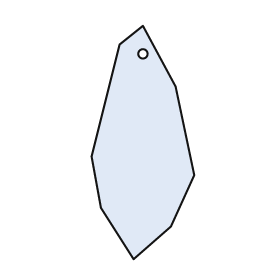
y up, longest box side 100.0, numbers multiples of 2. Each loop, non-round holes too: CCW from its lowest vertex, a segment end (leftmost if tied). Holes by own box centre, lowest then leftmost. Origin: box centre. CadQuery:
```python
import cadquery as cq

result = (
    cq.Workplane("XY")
    .moveTo(-4.0, -50.0)
    .lineTo(12.0, -36.0)
    .lineTo(22.0, -14.0)
    .lineTo(14.0, 24.0)
    .lineTo(0.0, 50.0)
    .lineTo(-10.0, 42.0)
    .lineTo(-22.0, -6.0)
    .lineTo(-18.0, -28.0)
    .close()
    .moveTo(0.0, 38.0)
    .circle(2.0)
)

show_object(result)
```